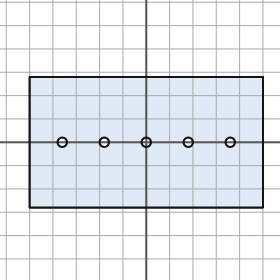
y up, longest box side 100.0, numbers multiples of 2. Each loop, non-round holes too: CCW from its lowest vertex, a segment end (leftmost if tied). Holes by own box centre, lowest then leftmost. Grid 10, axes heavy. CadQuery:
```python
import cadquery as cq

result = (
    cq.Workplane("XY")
    .moveTo(-50.0, -28.0)
    .lineTo(50.0, -28.0)
    .lineTo(50.0, 28.0)
    .lineTo(-50.0, 28.0)
    .close()
    .moveTo(-36.0, 0.0)
    .circle(2.0)
    .moveTo(-18.0, 0.0)
    .circle(2.0)
    .moveTo(0.0, 0.0)
    .circle(2.0)
    .moveTo(18.0, 0.0)
    .circle(2.0)
    .moveTo(36.0, 0.0)
    .circle(2.0)
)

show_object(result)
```